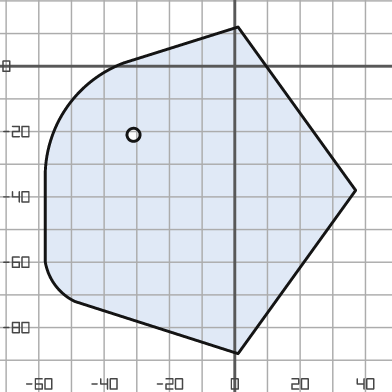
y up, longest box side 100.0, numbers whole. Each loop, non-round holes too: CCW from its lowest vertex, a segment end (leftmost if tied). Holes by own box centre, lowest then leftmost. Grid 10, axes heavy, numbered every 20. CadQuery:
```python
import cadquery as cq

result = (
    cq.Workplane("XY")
    .moveTo(1.0, -88.0)
    .lineTo(37.0, -38.0)
    .lineTo(1.0, 12.0)
    .lineTo(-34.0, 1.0)
    .threePointArc((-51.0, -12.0), (-58.0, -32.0))
    .lineTo(-58.0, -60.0)
    .threePointArc((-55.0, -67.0), (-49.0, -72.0))
    .close()
    .moveTo(-31.0, -21.0)
    .circle(2.0)
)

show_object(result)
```